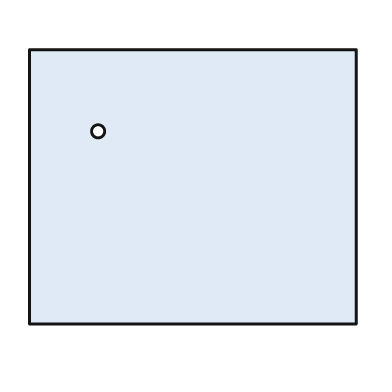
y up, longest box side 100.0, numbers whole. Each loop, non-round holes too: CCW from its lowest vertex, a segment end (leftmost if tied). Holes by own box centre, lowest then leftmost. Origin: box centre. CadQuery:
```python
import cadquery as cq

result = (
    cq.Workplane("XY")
    .moveTo(-50.0, -42.0)
    .lineTo(50.0, -42.0)
    .lineTo(50.0, 42.0)
    .lineTo(-50.0, 42.0)
    .close()
    .moveTo(-29.0, 17.0)
    .circle(2.0)
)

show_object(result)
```